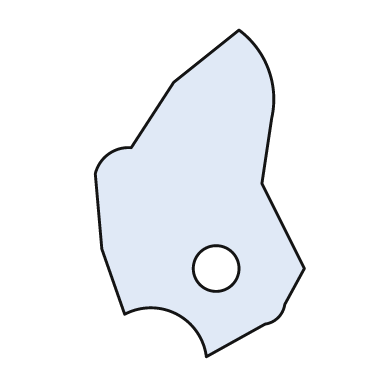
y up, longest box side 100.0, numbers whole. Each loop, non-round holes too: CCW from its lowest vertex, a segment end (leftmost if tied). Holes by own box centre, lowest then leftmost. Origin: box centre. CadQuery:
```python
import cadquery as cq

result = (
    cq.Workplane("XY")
    .moveTo(2.0, -50.0)
    .lineTo(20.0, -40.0)
    .threePointArc((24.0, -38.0), (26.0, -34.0))
    .lineTo(32.0, -23.0)
    .lineTo(19.0, 3.0)
    .lineTo(22.0, 23.0)
    .threePointArc((21.0, 38.0), (12.0, 50.0))
    .lineTo(-8.0, 34.0)
    .lineTo(-21.0, 14.0)
    .threePointArc((-28.0, 12.0), (-32.0, 6.0))
    .lineTo(-30.0, -17.0)
    .lineTo(-23.0, -37.0)
    .threePointArc((-7.0, -37.0), (2.0, -50.0))
    .close()
    .moveTo(5.0, -23.0)
    .circle(7.0)
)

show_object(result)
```